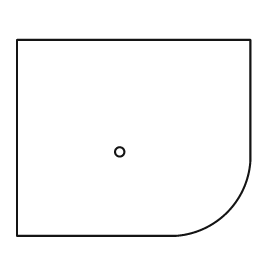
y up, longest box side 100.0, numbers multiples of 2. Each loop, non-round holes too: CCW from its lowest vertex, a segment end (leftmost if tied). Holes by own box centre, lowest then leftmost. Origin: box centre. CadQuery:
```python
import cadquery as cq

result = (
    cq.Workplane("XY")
    .moveTo(-50.0, -42.0)
    .lineTo(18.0, -42.0)
    .threePointArc((40.0, -32.0), (50.0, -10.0))
    .lineTo(50.0, 42.0)
    .lineTo(-50.0, 42.0)
    .close()
    .moveTo(-6.0, -6.0)
    .circle(2.0)
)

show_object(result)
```